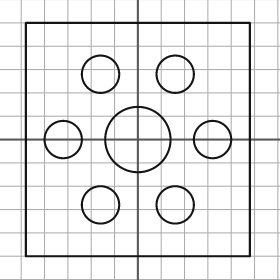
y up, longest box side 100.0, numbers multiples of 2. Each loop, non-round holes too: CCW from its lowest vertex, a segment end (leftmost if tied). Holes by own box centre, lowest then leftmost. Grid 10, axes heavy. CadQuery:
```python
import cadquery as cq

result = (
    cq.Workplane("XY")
    .moveTo(-48.0, -50.0)
    .lineTo(48.0, -50.0)
    .lineTo(48.0, 50.0)
    .lineTo(-48.0, 50.0)
    .close()
    .moveTo(-16.0, -28.0)
    .circle(8.0)
    .moveTo(16.0, -28.0)
    .circle(8.0)
    .moveTo(-32.0, 0.0)
    .circle(8.0)
    .moveTo(0.0, 0.0)
    .circle(14.0)
    .moveTo(32.0, 0.0)
    .circle(8.0)
    .moveTo(-16.0, 28.0)
    .circle(8.0)
    .moveTo(16.0, 28.0)
    .circle(8.0)
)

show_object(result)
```